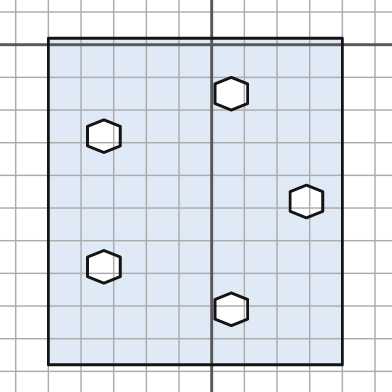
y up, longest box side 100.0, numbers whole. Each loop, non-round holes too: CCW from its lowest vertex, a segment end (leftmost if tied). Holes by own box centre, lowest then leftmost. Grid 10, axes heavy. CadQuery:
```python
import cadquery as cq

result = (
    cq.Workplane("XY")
    .moveTo(-50.0, -98.0)
    .lineTo(40.0, -98.0)
    .lineTo(40.0, 2.0)
    .lineTo(-50.0, 2.0)
    .close()
    .moveTo(6.0, -86.0)
    .lineTo(11.0, -84.0)
    .lineTo(11.0, -78.0)
    .lineTo(6.0, -76.0)
    .lineTo(1.0, -78.0)
    .lineTo(1.0, -84.0)
    .close()
    .moveTo(-33.0, -73.0)
    .lineTo(-28.0, -71.0)
    .lineTo(-28.0, -65.0)
    .lineTo(-33.0, -63.0)
    .lineTo(-38.0, -65.0)
    .lineTo(-38.0, -71.0)
    .close()
    .moveTo(29.0, -53.0)
    .lineTo(34.0, -51.0)
    .lineTo(34.0, -45.0)
    .lineTo(29.0, -43.0)
    .lineTo(24.0, -45.0)
    .lineTo(24.0, -51.0)
    .close()
    .moveTo(-33.0, -33.0)
    .lineTo(-28.0, -31.0)
    .lineTo(-28.0, -25.0)
    .lineTo(-33.0, -23.0)
    .lineTo(-38.0, -25.0)
    .lineTo(-38.0, -31.0)
    .close()
    .moveTo(6.0, -20.0)
    .lineTo(11.0, -18.0)
    .lineTo(11.0, -12.0)
    .lineTo(6.0, -10.0)
    .lineTo(1.0, -12.0)
    .lineTo(1.0, -18.0)
    .close()
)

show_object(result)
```